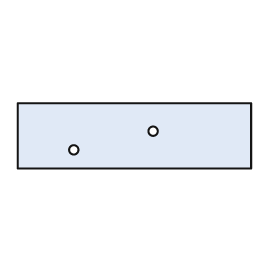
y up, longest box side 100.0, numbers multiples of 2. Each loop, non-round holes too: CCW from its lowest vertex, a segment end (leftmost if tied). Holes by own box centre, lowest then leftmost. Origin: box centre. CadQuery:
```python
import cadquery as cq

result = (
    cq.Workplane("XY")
    .moveTo(-50.0, -14.0)
    .lineTo(50.0, -14.0)
    .lineTo(50.0, 14.0)
    .lineTo(-50.0, 14.0)
    .close()
    .moveTo(-26.0, -6.0)
    .circle(2.0)
    .moveTo(8.0, 2.0)
    .circle(2.0)
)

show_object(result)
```